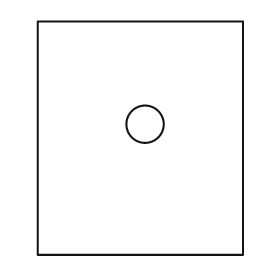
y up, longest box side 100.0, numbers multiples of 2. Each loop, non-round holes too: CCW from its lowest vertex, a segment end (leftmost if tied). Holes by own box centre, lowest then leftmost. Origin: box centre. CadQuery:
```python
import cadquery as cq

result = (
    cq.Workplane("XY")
    .moveTo(-44.0, -50.0)
    .lineTo(44.0, -50.0)
    .lineTo(44.0, 50.0)
    .lineTo(-44.0, 50.0)
    .close()
    .moveTo(2.0, 6.0)
    .circle(8.0)
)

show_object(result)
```